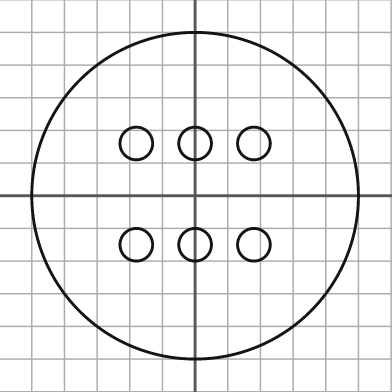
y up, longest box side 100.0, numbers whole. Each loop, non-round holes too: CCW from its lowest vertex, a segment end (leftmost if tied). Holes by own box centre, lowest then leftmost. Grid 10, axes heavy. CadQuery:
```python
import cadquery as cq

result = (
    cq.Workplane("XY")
    .moveTo(0.0, 0.0)
    .circle(50.0)
    .moveTo(-18.0, -15.0)
    .circle(5.0)
    .moveTo(0.0, -15.0)
    .circle(5.0)
    .moveTo(18.0, -15.0)
    .circle(5.0)
    .moveTo(-18.0, 16.0)
    .circle(5.0)
    .moveTo(0.0, 16.0)
    .circle(5.0)
    .moveTo(18.0, 16.0)
    .circle(5.0)
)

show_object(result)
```